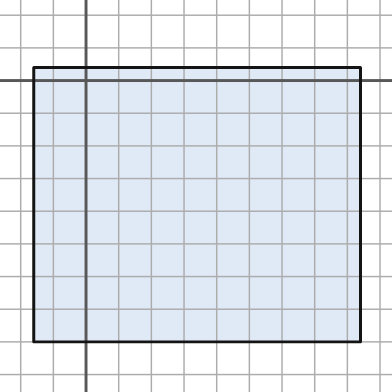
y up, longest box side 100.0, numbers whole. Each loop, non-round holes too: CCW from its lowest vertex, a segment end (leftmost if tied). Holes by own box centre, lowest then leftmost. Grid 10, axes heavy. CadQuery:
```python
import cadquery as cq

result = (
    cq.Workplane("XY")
    .moveTo(-16.0, -80.0)
    .lineTo(84.0, -80.0)
    .lineTo(84.0, 4.0)
    .lineTo(-16.0, 4.0)
    .close()
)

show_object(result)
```